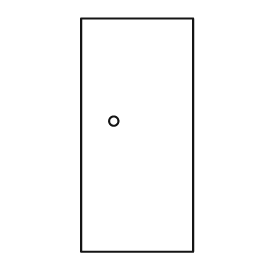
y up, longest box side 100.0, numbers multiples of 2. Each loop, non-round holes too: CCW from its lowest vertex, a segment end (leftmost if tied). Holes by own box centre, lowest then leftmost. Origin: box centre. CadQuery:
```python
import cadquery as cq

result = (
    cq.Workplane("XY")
    .moveTo(-24.0, -50.0)
    .lineTo(24.0, -50.0)
    .lineTo(24.0, 50.0)
    .lineTo(-24.0, 50.0)
    .close()
    .moveTo(-10.0, 6.0)
    .circle(2.0)
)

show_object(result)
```